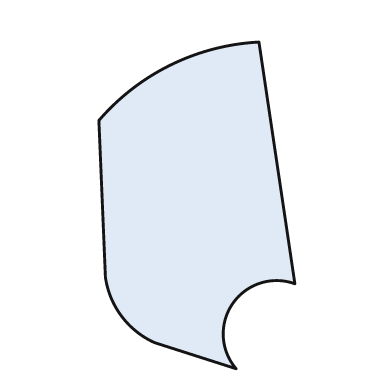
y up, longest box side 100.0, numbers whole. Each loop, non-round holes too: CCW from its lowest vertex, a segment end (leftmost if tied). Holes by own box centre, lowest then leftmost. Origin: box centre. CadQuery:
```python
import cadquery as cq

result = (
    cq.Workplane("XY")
    .moveTo(12.0, -50.0)
    .threePointArc((11.0, -30.0), (30.0, -24.0))
    .lineTo(19.0, 50.0)
    .threePointArc((-8.0, 43.0), (-30.0, 26.0))
    .lineTo(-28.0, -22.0)
    .threePointArc((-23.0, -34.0), (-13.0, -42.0))
    .close()
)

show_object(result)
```